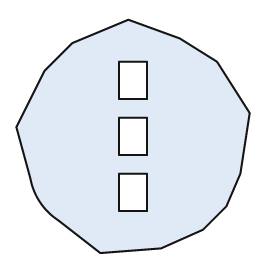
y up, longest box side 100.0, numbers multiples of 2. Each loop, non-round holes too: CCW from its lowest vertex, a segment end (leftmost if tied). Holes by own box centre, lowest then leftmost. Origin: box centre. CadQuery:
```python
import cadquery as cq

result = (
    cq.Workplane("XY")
    .moveTo(-14.0, -50.0)
    .lineTo(12.0, -48.0)
    .lineTo(30.0, -40.0)
    .lineTo(40.0, -30.0)
    .lineTo(46.0, -16.0)
    .lineTo(50.0, 10.0)
    .lineTo(36.0, 32.0)
    .lineTo(20.0, 42.0)
    .lineTo(-2.0, 50.0)
    .lineTo(-26.0, 40.0)
    .lineTo(-38.0, 28.0)
    .lineTo(-50.0, 4.0)
    .lineTo(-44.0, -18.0)
    .threePointArc((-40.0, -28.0), (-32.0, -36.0))
    .close()
    .moveTo(-6.0, -32.0)
    .lineTo(6.0, -32.0)
    .lineTo(6.0, -16.0)
    .lineTo(-6.0, -16.0)
    .close()
    .moveTo(-6.0, -8.0)
    .lineTo(6.0, -8.0)
    .lineTo(6.0, 8.0)
    .lineTo(-6.0, 8.0)
    .close()
    .moveTo(-6.0, 16.0)
    .lineTo(6.0, 16.0)
    .lineTo(6.0, 32.0)
    .lineTo(-6.0, 32.0)
    .close()
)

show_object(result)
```